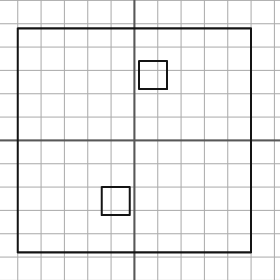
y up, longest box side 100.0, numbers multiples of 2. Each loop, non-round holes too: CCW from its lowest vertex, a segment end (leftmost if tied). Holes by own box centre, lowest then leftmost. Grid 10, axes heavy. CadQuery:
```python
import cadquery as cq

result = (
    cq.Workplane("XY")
    .moveTo(-50.0, -48.0)
    .lineTo(50.0, -48.0)
    .lineTo(50.0, 48.0)
    .lineTo(-50.0, 48.0)
    .close()
    .moveTo(-14.0, -32.0)
    .lineTo(-2.0, -32.0)
    .lineTo(-2.0, -20.0)
    .lineTo(-14.0, -20.0)
    .close()
    .moveTo(2.0, 22.0)
    .lineTo(14.0, 22.0)
    .lineTo(14.0, 34.0)
    .lineTo(2.0, 34.0)
    .close()
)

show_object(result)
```